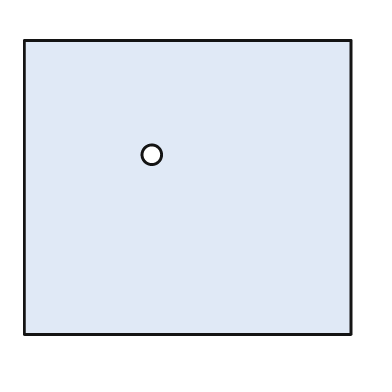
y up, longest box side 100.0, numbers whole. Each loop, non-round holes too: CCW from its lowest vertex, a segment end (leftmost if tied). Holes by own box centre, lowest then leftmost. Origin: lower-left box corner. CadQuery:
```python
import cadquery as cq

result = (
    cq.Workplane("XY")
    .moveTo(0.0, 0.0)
    .lineTo(100.0, 0.0)
    .lineTo(100.0, 90.0)
    .lineTo(0.0, 90.0)
    .close()
    .moveTo(39.0, 55.0)
    .circle(3.0)
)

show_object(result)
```